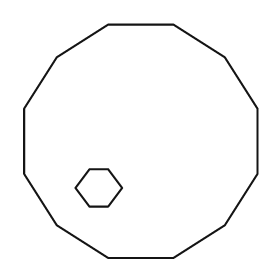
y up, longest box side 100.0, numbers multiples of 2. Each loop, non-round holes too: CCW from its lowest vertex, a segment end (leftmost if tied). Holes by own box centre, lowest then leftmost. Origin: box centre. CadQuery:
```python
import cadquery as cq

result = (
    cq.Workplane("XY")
    .moveTo(-14.0, -50.0)
    .lineTo(14.0, -50.0)
    .lineTo(36.0, -36.0)
    .lineTo(50.0, -14.0)
    .lineTo(50.0, 14.0)
    .lineTo(36.0, 36.0)
    .lineTo(14.0, 50.0)
    .lineTo(-14.0, 50.0)
    .lineTo(-36.0, 36.0)
    .lineTo(-50.0, 14.0)
    .lineTo(-50.0, -14.0)
    .lineTo(-36.0, -36.0)
    .close()
    .moveTo(-22.0, -28.0)
    .lineTo(-14.0, -28.0)
    .lineTo(-8.0, -20.0)
    .lineTo(-14.0, -12.0)
    .lineTo(-22.0, -12.0)
    .lineTo(-28.0, -20.0)
    .close()
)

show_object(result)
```